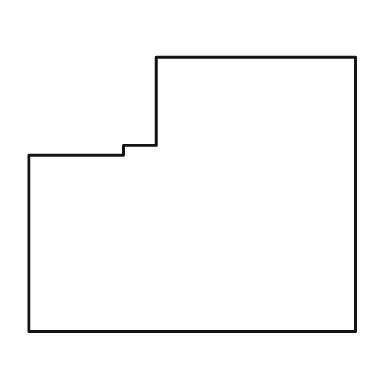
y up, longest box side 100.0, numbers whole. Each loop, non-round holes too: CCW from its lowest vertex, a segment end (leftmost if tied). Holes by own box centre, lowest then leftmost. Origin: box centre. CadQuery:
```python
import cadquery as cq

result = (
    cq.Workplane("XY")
    .moveTo(-50.0, -42.0)
    .lineTo(50.0, -42.0)
    .lineTo(50.0, 42.0)
    .lineTo(-11.0, 42.0)
    .lineTo(-11.0, 15.0)
    .lineTo(-21.0, 15.0)
    .lineTo(-21.0, 12.0)
    .lineTo(-50.0, 12.0)
    .close()
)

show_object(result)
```